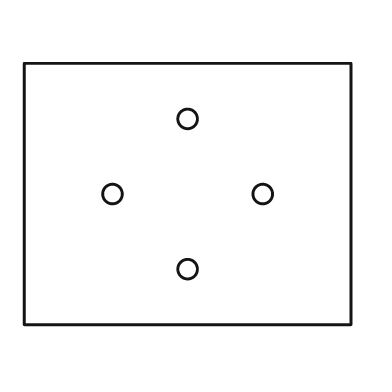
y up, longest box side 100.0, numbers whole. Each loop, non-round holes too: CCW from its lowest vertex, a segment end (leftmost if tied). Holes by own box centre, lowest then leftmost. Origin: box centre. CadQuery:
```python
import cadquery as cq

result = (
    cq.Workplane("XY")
    .moveTo(-50.0, -40.0)
    .lineTo(50.0, -40.0)
    .lineTo(50.0, 40.0)
    .lineTo(-50.0, 40.0)
    .close()
    .moveTo(0.0, -23.0)
    .circle(3.0)
    .moveTo(-23.0, 0.0)
    .circle(3.0)
    .moveTo(23.0, 0.0)
    .circle(3.0)
    .moveTo(0.0, 23.0)
    .circle(3.0)
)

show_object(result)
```